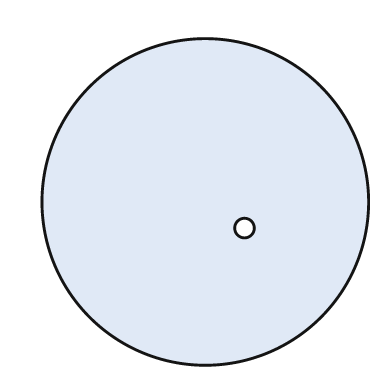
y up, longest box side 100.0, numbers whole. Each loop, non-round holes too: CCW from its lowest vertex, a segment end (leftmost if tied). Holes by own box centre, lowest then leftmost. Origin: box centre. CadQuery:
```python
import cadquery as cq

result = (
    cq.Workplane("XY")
    .moveTo(0.0, 0.0)
    .circle(50.0)
    .moveTo(12.0, -8.0)
    .circle(3.0)
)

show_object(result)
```